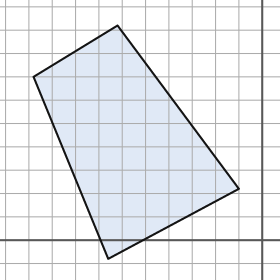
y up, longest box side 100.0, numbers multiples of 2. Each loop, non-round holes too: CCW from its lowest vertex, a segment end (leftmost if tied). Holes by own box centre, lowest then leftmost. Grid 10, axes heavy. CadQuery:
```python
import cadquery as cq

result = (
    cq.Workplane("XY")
    .moveTo(-66.0, -8.0)
    .lineTo(-10.0, 22.0)
    .lineTo(-62.0, 92.0)
    .lineTo(-98.0, 70.0)
    .close()
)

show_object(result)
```